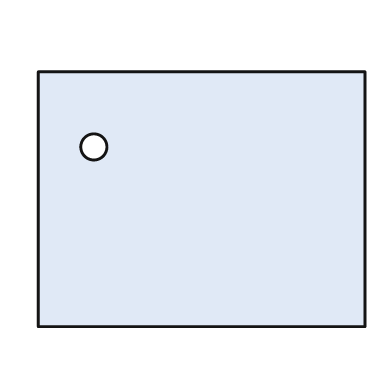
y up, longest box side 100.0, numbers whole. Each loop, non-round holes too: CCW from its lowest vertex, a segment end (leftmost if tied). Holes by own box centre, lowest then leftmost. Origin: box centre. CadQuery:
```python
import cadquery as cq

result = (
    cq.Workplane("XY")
    .moveTo(-50.0, -39.0)
    .lineTo(50.0, -39.0)
    .lineTo(50.0, 39.0)
    .lineTo(-50.0, 39.0)
    .close()
    .moveTo(-33.0, 16.0)
    .circle(4.0)
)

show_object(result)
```